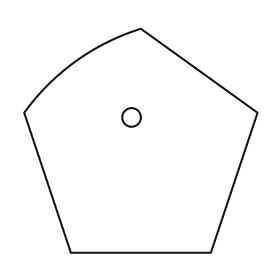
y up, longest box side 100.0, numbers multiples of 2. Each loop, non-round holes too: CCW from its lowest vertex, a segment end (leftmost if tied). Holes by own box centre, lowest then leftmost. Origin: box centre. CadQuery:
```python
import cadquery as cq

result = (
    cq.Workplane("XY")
    .moveTo(-30.0, -48.0)
    .lineTo(30.0, -48.0)
    .lineTo(50.0, 12.0)
    .lineTo(0.0, 48.0)
    .threePointArc((-28.0, 34.0), (-50.0, 12.0))
    .close()
    .moveTo(-4.0, 10.0)
    .circle(4.0)
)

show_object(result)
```